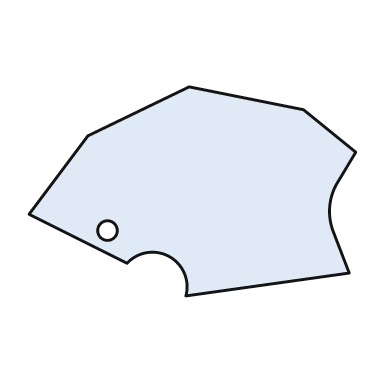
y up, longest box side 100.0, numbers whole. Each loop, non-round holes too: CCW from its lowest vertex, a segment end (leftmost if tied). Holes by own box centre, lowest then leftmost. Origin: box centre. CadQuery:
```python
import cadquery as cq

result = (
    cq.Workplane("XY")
    .moveTo(-2.0, -32.0)
    .lineTo(48.0, -25.0)
    .lineTo(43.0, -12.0)
    .threePointArc((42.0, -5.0), (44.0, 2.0))
    .lineTo(50.0, 12.0)
    .lineTo(34.0, 25.0)
    .lineTo(-1.0, 32.0)
    .lineTo(-32.0, 17.0)
    .lineTo(-50.0, -7.0)
    .lineTo(-20.0, -22.0)
    .threePointArc((-7.0, -20.0), (-2.0, -32.0))
    .close()
    .moveTo(-26.0, -12.0)
    .circle(3.0)
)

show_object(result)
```